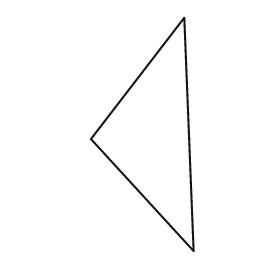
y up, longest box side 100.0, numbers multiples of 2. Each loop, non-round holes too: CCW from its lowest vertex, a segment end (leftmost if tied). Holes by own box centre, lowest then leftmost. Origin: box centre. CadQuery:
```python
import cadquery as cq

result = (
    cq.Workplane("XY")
    .moveTo(22.0, -50.0)
    .lineTo(18.0, 50.0)
    .lineTo(-22.0, -2.0)
    .close()
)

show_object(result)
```